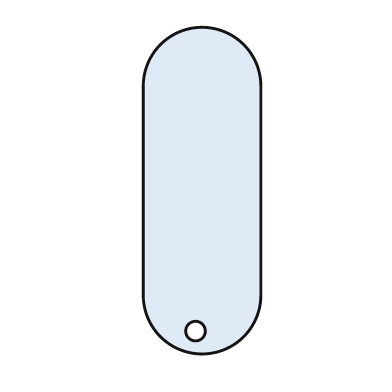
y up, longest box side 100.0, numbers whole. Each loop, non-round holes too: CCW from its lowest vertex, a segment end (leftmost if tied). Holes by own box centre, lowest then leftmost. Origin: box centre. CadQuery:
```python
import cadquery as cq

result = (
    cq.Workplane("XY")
    .moveTo(-18.0, -32.0)
    .threePointArc((0.0, -50.0), (18.0, -32.0))
    .lineTo(18.0, 32.0)
    .threePointArc((0.0, 50.0), (-18.0, 32.0))
    .close()
    .moveTo(-2.0, -43.0)
    .circle(3.0)
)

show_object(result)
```